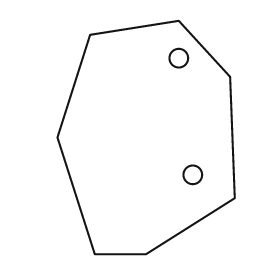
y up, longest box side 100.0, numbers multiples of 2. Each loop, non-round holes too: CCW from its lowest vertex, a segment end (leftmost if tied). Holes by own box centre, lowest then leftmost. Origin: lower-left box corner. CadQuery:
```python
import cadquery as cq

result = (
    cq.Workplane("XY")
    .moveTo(16.0, 0.0)
    .lineTo(38.0, 0.0)
    .lineTo(76.0, 24.0)
    .lineTo(74.0, 76.0)
    .lineTo(52.0, 100.0)
    .lineTo(14.0, 94.0)
    .lineTo(0.0, 50.0)
    .close()
    .moveTo(58.0, 34.0)
    .circle(4.0)
    .moveTo(52.0, 84.0)
    .circle(4.0)
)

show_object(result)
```